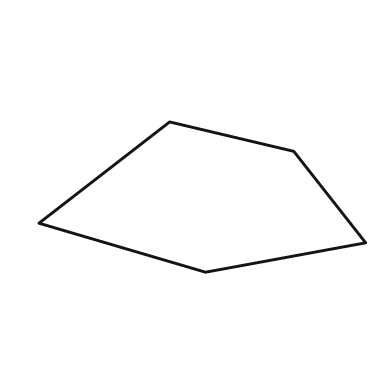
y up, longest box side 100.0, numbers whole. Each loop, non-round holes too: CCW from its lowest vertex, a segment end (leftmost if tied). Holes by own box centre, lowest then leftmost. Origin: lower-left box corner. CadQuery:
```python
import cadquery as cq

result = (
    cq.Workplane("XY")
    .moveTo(51.0, 0.0)
    .lineTo(100.0, 9.0)
    .lineTo(78.0, 37.0)
    .lineTo(40.0, 46.0)
    .lineTo(0.0, 15.0)
    .close()
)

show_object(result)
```